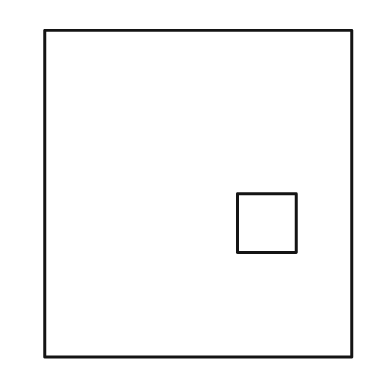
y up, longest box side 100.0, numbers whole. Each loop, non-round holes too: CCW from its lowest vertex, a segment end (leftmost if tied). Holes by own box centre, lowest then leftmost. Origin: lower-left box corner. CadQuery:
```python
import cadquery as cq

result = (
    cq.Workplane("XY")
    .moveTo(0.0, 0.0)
    .lineTo(94.0, 0.0)
    .lineTo(94.0, 100.0)
    .lineTo(0.0, 100.0)
    .close()
    .moveTo(59.0, 32.0)
    .lineTo(77.0, 32.0)
    .lineTo(77.0, 50.0)
    .lineTo(59.0, 50.0)
    .close()
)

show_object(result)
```